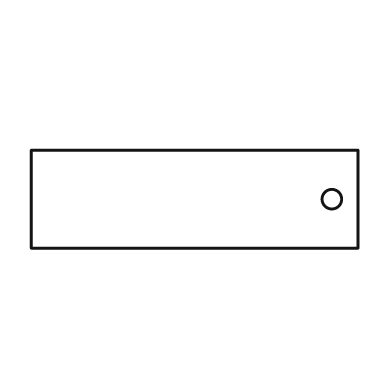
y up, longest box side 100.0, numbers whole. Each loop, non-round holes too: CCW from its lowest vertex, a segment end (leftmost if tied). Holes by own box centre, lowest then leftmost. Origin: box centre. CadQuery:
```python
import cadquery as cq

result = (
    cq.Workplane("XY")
    .moveTo(-50.0, -15.0)
    .lineTo(50.0, -15.0)
    .lineTo(50.0, 15.0)
    .lineTo(-50.0, 15.0)
    .close()
    .moveTo(42.0, 0.0)
    .circle(3.0)
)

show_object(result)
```